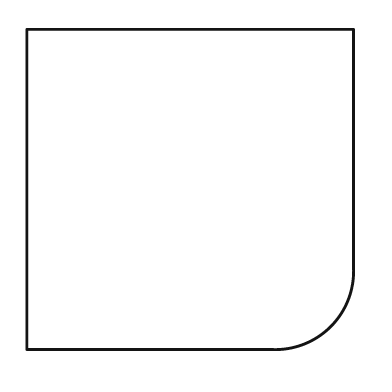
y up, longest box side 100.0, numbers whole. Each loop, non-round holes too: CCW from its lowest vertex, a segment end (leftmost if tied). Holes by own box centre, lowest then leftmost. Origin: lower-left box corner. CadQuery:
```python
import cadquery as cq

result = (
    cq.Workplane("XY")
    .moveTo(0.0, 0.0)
    .lineTo(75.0, 0.0)
    .threePointArc((93.0, 7.0), (100.0, 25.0))
    .lineTo(100.0, 98.0)
    .lineTo(0.0, 98.0)
    .close()
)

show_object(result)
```